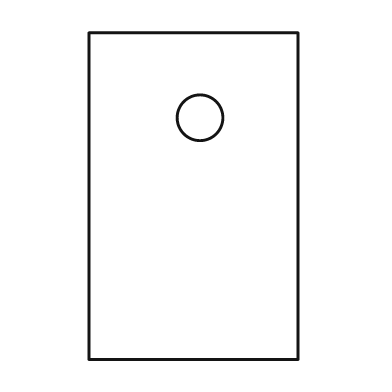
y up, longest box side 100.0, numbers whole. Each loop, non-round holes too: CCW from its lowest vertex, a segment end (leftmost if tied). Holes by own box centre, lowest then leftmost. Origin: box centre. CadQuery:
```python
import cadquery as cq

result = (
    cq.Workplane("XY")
    .moveTo(-32.0, -50.0)
    .lineTo(32.0, -50.0)
    .lineTo(32.0, 50.0)
    .lineTo(-32.0, 50.0)
    .close()
    .moveTo(2.0, 24.0)
    .circle(7.0)
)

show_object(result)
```